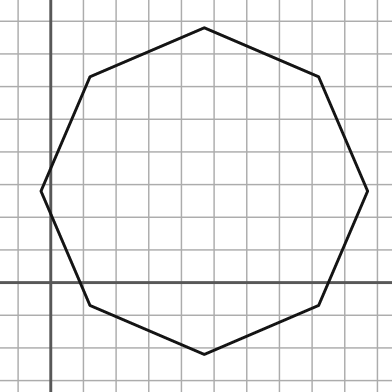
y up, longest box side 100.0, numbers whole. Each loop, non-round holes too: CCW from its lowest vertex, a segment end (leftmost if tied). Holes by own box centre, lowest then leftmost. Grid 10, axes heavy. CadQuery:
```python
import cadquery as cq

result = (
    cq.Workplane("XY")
    .moveTo(47.0, -22.0)
    .lineTo(82.0, -7.0)
    .lineTo(97.0, 28.0)
    .lineTo(82.0, 63.0)
    .lineTo(47.0, 78.0)
    .lineTo(12.0, 63.0)
    .lineTo(-3.0, 28.0)
    .lineTo(12.0, -7.0)
    .close()
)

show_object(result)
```